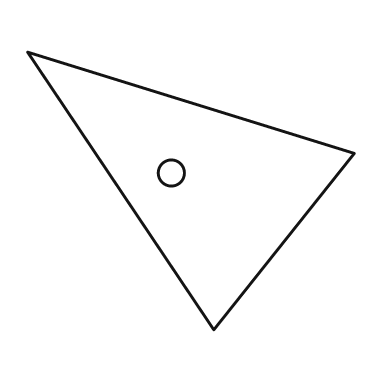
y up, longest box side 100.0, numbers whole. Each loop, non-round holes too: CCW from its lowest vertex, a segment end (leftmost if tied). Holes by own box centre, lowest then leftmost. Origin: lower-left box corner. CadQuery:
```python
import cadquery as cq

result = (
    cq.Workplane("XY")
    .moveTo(57.0, 0.0)
    .lineTo(100.0, 54.0)
    .lineTo(0.0, 85.0)
    .close()
    .moveTo(44.0, 48.0)
    .circle(4.0)
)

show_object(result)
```